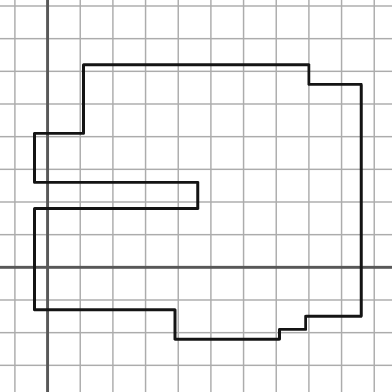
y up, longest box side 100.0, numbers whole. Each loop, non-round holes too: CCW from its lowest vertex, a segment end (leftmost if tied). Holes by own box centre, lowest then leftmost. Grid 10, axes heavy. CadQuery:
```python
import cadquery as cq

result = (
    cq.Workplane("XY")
    .moveTo(39.0, -22.0)
    .lineTo(71.0, -22.0)
    .lineTo(71.0, -19.0)
    .lineTo(79.0, -19.0)
    .lineTo(79.0, -15.0)
    .lineTo(96.0, -15.0)
    .lineTo(96.0, 56.0)
    .lineTo(80.0, 56.0)
    .lineTo(80.0, 62.0)
    .lineTo(11.0, 62.0)
    .lineTo(11.0, 41.0)
    .lineTo(-4.0, 41.0)
    .lineTo(-4.0, 26.0)
    .lineTo(46.0, 26.0)
    .lineTo(46.0, 18.0)
    .lineTo(-4.0, 18.0)
    .lineTo(-4.0, -13.0)
    .lineTo(39.0, -13.0)
    .close()
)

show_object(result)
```